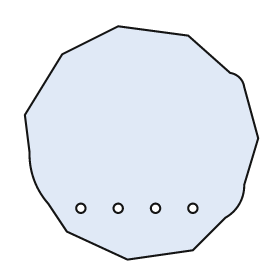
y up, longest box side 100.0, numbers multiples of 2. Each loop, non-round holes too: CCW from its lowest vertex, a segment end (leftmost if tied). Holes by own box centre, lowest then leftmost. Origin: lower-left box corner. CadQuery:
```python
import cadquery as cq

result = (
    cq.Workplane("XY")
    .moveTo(44.0, 0.0)
    .lineTo(72.0, 4.0)
    .lineTo(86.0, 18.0)
    .threePointArc((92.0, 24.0), (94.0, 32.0))
    .lineTo(100.0, 52.0)
    .lineTo(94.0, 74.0)
    .threePointArc((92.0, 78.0), (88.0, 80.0))
    .lineTo(70.0, 96.0)
    .lineTo(40.0, 100.0)
    .lineTo(16.0, 88.0)
    .lineTo(0.0, 62.0)
    .lineTo(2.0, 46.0)
    .threePointArc((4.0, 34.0), (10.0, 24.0))
    .lineTo(18.0, 12.0)
    .close()
    .moveTo(24.0, 22.0)
    .circle(2.0)
    .moveTo(40.0, 22.0)
    .circle(2.0)
    .moveTo(56.0, 22.0)
    .circle(2.0)
    .moveTo(72.0, 22.0)
    .circle(2.0)
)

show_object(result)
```